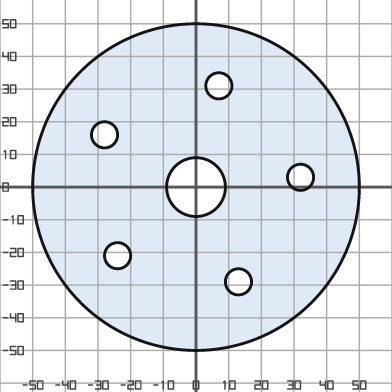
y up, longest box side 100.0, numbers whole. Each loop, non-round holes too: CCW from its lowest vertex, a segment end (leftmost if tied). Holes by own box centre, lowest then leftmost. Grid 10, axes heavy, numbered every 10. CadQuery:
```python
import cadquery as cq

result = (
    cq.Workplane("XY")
    .moveTo(0.0, 0.0)
    .circle(50.0)
    .moveTo(13.0, -29.0)
    .circle(4.0)
    .moveTo(-24.0, -21.0)
    .circle(4.0)
    .moveTo(0.0, 0.0)
    .circle(9.0)
    .moveTo(32.0, 3.0)
    .circle(4.0)
    .moveTo(-28.0, 16.0)
    .circle(4.0)
    .moveTo(7.0, 31.0)
    .circle(4.0)
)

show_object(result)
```